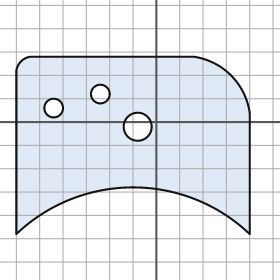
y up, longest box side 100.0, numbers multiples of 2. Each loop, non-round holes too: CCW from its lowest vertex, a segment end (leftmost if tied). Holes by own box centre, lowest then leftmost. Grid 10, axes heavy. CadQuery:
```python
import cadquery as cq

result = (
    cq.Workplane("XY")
    .moveTo(-60.0, -48.0)
    .threePointArc((-10.0, -28.0), (40.0, -48.0))
    .lineTo(40.0, 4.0)
    .threePointArc((32.0, 20.0), (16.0, 28.0))
    .lineTo(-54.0, 28.0)
    .threePointArc((-58.0, 26.0), (-60.0, 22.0))
    .close()
    .moveTo(-8.0, -2.0)
    .circle(6.0)
    .moveTo(-44.0, 6.0)
    .circle(4.0)
    .moveTo(-24.0, 12.0)
    .circle(4.0)
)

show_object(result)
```